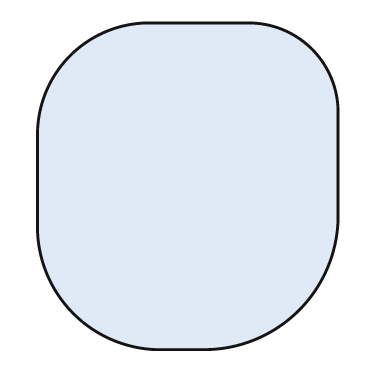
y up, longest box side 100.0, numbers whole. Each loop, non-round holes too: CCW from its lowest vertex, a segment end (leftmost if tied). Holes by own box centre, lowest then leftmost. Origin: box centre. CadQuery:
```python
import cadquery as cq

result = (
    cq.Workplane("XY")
    .moveTo(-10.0, -50.0)
    .lineTo(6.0, -50.0)
    .threePointArc((34.0, -38.0), (46.0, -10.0))
    .lineTo(46.0, 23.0)
    .threePointArc((38.0, 42.0), (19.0, 50.0))
    .lineTo(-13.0, 50.0)
    .threePointArc((-36.0, 40.0), (-46.0, 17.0))
    .lineTo(-46.0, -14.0)
    .threePointArc((-35.0, -39.0), (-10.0, -50.0))
    .close()
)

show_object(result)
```